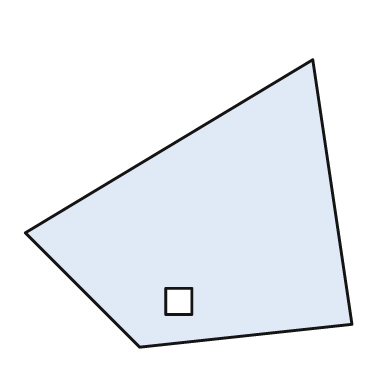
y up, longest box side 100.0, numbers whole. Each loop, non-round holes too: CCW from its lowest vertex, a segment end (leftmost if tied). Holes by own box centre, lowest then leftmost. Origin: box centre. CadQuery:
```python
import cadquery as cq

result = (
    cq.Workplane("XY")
    .moveTo(-15.0, -44.0)
    .lineTo(50.0, -37.0)
    .lineTo(38.0, 44.0)
    .lineTo(-50.0, -9.0)
    .close()
    .moveTo(-7.0, -34.0)
    .lineTo(1.0, -34.0)
    .lineTo(1.0, -26.0)
    .lineTo(-7.0, -26.0)
    .close()
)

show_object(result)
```